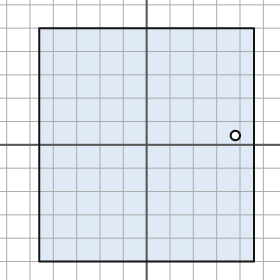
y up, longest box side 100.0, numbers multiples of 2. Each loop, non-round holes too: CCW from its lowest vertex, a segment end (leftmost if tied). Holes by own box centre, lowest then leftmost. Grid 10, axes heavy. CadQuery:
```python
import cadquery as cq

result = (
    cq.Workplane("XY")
    .moveTo(-46.0, -50.0)
    .lineTo(46.0, -50.0)
    .lineTo(46.0, 50.0)
    .lineTo(-46.0, 50.0)
    .close()
    .moveTo(38.0, 4.0)
    .circle(2.0)
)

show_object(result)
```